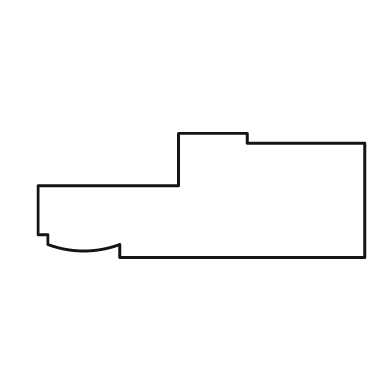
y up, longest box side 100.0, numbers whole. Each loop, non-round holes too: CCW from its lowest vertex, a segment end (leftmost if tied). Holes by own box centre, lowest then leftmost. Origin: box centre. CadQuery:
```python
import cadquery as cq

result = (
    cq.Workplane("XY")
    .moveTo(-25.0, -19.0)
    .lineTo(50.0, -19.0)
    .lineTo(50.0, 16.0)
    .lineTo(14.0, 16.0)
    .lineTo(14.0, 19.0)
    .lineTo(-7.0, 19.0)
    .lineTo(-7.0, 3.0)
    .lineTo(-50.0, 3.0)
    .lineTo(-50.0, -12.0)
    .lineTo(-47.0, -12.0)
    .lineTo(-47.0, -15.0)
    .threePointArc((-36.0, -17.0), (-25.0, -15.0))
    .close()
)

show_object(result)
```